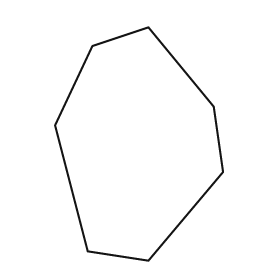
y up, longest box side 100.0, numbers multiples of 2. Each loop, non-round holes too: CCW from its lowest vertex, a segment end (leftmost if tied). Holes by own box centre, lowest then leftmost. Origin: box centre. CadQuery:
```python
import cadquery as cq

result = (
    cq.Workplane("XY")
    .moveTo(4.0, -50.0)
    .lineTo(36.0, -12.0)
    .lineTo(32.0, 16.0)
    .lineTo(4.0, 50.0)
    .lineTo(-20.0, 42.0)
    .lineTo(-36.0, 8.0)
    .lineTo(-22.0, -46.0)
    .close()
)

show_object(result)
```